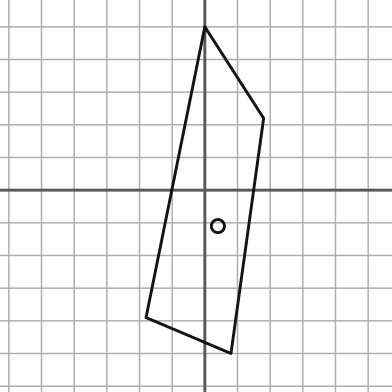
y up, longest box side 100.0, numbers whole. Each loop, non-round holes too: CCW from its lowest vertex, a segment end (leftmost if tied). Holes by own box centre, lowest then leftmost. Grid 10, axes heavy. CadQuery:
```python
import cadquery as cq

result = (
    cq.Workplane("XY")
    .moveTo(8.0, -50.0)
    .lineTo(18.0, 22.0)
    .lineTo(0.0, 50.0)
    .lineTo(-18.0, -39.0)
    .close()
    .moveTo(4.0, -11.0)
    .circle(2.0)
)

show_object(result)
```